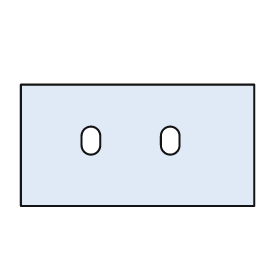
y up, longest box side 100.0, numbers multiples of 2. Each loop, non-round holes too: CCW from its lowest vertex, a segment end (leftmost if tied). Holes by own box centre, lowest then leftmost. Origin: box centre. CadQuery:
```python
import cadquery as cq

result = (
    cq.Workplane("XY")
    .moveTo(-50.0, -26.0)
    .lineTo(50.0, -26.0)
    .lineTo(50.0, 26.0)
    .lineTo(-50.0, 26.0)
    .close()
    .moveTo(-24.0, 0.0)
    .threePointArc((-20.0, -4.0), (-16.0, 0.0))
    .lineTo(-16.0, 4.0)
    .threePointArc((-20.0, 8.0), (-24.0, 4.0))
    .close()
    .moveTo(10.0, 0.0)
    .threePointArc((14.0, -4.0), (18.0, 0.0))
    .lineTo(18.0, 4.0)
    .threePointArc((14.0, 8.0), (10.0, 4.0))
    .close()
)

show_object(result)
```